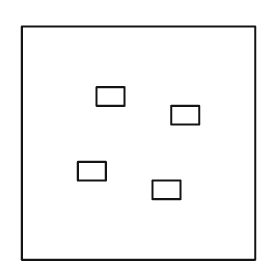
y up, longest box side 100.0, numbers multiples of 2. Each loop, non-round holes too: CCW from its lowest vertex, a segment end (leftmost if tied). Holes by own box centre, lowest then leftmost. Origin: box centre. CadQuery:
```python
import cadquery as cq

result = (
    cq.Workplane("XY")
    .moveTo(-50.0, -50.0)
    .lineTo(50.0, -50.0)
    .lineTo(50.0, 50.0)
    .lineTo(-50.0, 50.0)
    .close()
    .moveTo(6.0, -24.0)
    .lineTo(18.0, -24.0)
    .lineTo(18.0, -16.0)
    .lineTo(6.0, -16.0)
    .close()
    .moveTo(-26.0, -16.0)
    .lineTo(-14.0, -16.0)
    .lineTo(-14.0, -8.0)
    .lineTo(-26.0, -8.0)
    .close()
    .moveTo(14.0, 8.0)
    .lineTo(26.0, 8.0)
    .lineTo(26.0, 16.0)
    .lineTo(14.0, 16.0)
    .close()
    .moveTo(-18.0, 16.0)
    .lineTo(-6.0, 16.0)
    .lineTo(-6.0, 24.0)
    .lineTo(-18.0, 24.0)
    .close()
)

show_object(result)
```